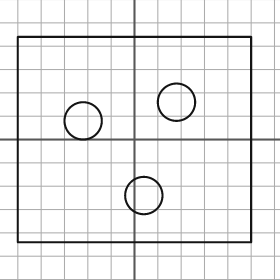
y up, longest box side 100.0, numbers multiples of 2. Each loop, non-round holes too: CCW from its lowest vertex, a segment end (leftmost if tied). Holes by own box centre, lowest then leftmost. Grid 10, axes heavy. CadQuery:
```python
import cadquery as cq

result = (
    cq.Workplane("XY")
    .moveTo(-50.0, -44.0)
    .lineTo(50.0, -44.0)
    .lineTo(50.0, 44.0)
    .lineTo(-50.0, 44.0)
    .close()
    .moveTo(4.0, -24.0)
    .circle(8.0)
    .moveTo(-22.0, 8.0)
    .circle(8.0)
    .moveTo(18.0, 16.0)
    .circle(8.0)
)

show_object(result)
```